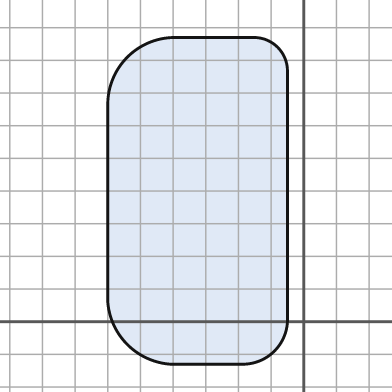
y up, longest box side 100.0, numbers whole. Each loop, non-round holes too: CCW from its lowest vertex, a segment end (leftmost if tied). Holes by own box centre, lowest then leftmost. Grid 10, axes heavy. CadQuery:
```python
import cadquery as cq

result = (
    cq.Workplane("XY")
    .moveTo(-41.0, -13.0)
    .lineTo(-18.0, -13.0)
    .threePointArc((-9.0, -9.0), (-5.0, 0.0))
    .lineTo(-5.0, 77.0)
    .threePointArc((-8.0, 84.0), (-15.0, 87.0))
    .lineTo(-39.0, 87.0)
    .threePointArc((-54.0, 81.0), (-60.0, 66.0))
    .lineTo(-60.0, 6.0)
    .threePointArc((-54.0, -7.0), (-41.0, -13.0))
    .close()
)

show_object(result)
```